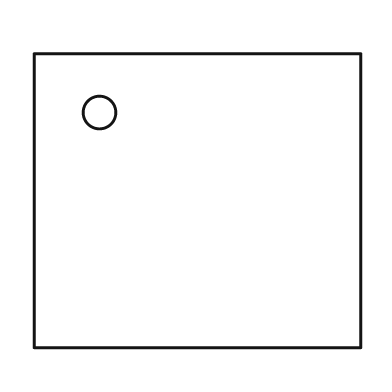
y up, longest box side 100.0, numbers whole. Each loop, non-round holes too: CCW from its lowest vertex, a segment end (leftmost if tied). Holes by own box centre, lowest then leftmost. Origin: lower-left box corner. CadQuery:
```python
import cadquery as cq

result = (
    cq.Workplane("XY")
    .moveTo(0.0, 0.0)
    .lineTo(100.0, 0.0)
    .lineTo(100.0, 90.0)
    .lineTo(0.0, 90.0)
    .close()
    .moveTo(20.0, 72.0)
    .circle(5.0)
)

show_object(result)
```